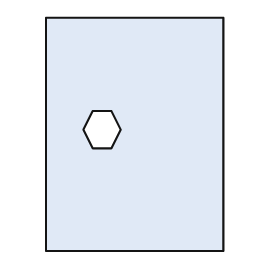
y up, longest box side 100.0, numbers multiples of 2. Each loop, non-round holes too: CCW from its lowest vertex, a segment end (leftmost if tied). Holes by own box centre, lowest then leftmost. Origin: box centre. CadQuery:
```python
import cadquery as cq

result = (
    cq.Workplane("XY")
    .moveTo(-38.0, -50.0)
    .lineTo(38.0, -50.0)
    .lineTo(38.0, 50.0)
    .lineTo(-38.0, 50.0)
    .close()
    .moveTo(-18.0, -6.0)
    .lineTo(-10.0, -6.0)
    .lineTo(-6.0, 2.0)
    .lineTo(-10.0, 10.0)
    .lineTo(-18.0, 10.0)
    .lineTo(-22.0, 2.0)
    .close()
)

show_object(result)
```